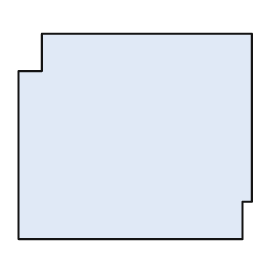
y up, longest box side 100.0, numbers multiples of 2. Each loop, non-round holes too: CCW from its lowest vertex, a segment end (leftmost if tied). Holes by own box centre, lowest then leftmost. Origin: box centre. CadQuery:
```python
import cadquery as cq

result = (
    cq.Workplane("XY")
    .moveTo(-50.0, -44.0)
    .lineTo(46.0, -44.0)
    .lineTo(46.0, -28.0)
    .lineTo(50.0, -28.0)
    .lineTo(50.0, 44.0)
    .lineTo(-40.0, 44.0)
    .lineTo(-40.0, 28.0)
    .lineTo(-50.0, 28.0)
    .close()
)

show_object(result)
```